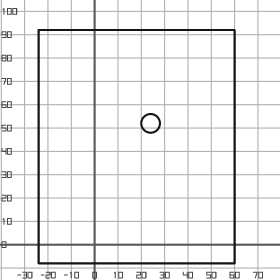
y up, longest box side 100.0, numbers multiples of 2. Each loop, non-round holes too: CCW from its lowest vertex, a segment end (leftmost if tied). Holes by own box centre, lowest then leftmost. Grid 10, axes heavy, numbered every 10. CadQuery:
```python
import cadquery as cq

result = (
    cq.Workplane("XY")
    .moveTo(-24.0, -8.0)
    .lineTo(60.0, -8.0)
    .lineTo(60.0, 92.0)
    .lineTo(-24.0, 92.0)
    .close()
    .moveTo(24.0, 52.0)
    .circle(4.0)
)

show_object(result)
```